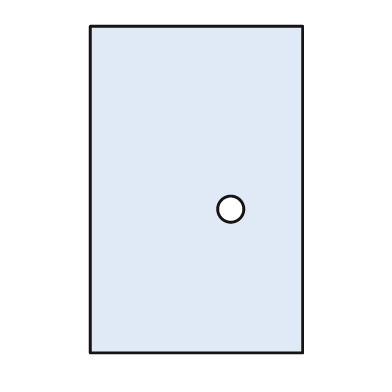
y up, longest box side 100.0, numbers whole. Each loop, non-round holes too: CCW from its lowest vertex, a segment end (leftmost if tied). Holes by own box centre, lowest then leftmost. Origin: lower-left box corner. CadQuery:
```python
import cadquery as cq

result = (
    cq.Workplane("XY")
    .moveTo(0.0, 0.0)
    .lineTo(65.0, 0.0)
    .lineTo(65.0, 100.0)
    .lineTo(0.0, 100.0)
    .close()
    .moveTo(43.0, 44.0)
    .circle(4.0)
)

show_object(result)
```